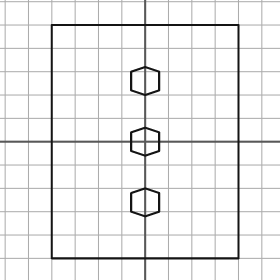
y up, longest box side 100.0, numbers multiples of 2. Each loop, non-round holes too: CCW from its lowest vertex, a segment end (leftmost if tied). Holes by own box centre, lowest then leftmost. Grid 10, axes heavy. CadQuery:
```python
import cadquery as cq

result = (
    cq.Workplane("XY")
    .moveTo(-40.0, -50.0)
    .lineTo(40.0, -50.0)
    .lineTo(40.0, 50.0)
    .lineTo(-40.0, 50.0)
    .close()
    .moveTo(0.0, -32.0)
    .lineTo(6.0, -30.0)
    .lineTo(6.0, -22.0)
    .lineTo(0.0, -20.0)
    .lineTo(-6.0, -22.0)
    .lineTo(-6.0, -30.0)
    .close()
    .moveTo(0.0, -6.0)
    .lineTo(6.0, -4.0)
    .lineTo(6.0, 4.0)
    .lineTo(0.0, 6.0)
    .lineTo(-6.0, 4.0)
    .lineTo(-6.0, -4.0)
    .close()
    .moveTo(0.0, 20.0)
    .lineTo(6.0, 22.0)
    .lineTo(6.0, 30.0)
    .lineTo(0.0, 32.0)
    .lineTo(-6.0, 30.0)
    .lineTo(-6.0, 22.0)
    .close()
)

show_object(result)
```